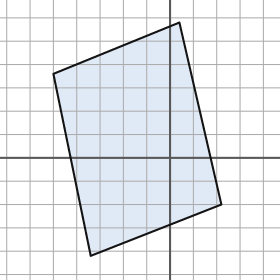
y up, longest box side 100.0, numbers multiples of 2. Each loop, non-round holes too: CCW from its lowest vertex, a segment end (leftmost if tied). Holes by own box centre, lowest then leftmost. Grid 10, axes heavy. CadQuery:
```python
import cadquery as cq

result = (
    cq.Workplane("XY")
    .moveTo(-34.0, -42.0)
    .lineTo(22.0, -20.0)
    .lineTo(4.0, 58.0)
    .lineTo(-50.0, 36.0)
    .close()
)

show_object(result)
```